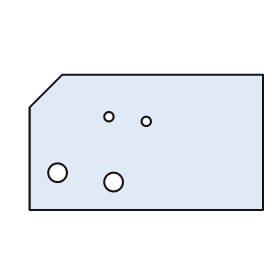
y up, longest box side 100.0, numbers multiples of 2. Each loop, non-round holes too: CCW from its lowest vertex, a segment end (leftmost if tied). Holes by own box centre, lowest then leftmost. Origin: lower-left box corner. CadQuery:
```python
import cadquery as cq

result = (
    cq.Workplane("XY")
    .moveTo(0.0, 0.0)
    .lineTo(100.0, 0.0)
    .lineTo(100.0, 58.0)
    .lineTo(14.0, 58.0)
    .lineTo(0.0, 44.0)
    .close()
    .moveTo(36.0, 12.0)
    .circle(4.0)
    .moveTo(12.0, 16.0)
    .circle(4.0)
    .moveTo(50.0, 38.0)
    .circle(2.0)
    .moveTo(34.0, 40.0)
    .circle(2.0)
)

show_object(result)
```